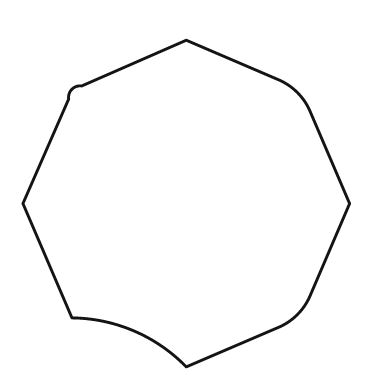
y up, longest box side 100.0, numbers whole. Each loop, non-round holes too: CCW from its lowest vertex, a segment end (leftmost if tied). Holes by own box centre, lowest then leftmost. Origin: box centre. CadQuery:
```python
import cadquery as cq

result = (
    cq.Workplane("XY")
    .moveTo(0.0, -50.0)
    .lineTo(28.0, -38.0)
    .threePointArc((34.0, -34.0), (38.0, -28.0))
    .lineTo(50.0, 0.0)
    .lineTo(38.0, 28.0)
    .threePointArc((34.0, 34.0), (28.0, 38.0))
    .lineTo(0.0, 50.0)
    .lineTo(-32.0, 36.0)
    .threePointArc((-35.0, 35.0), (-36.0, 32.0))
    .lineTo(-50.0, 0.0)
    .lineTo(-35.0, -35.0)
    .threePointArc((-16.0, -39.0), (0.0, -50.0))
    .close()
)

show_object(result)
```